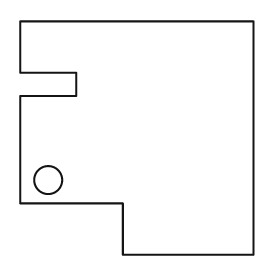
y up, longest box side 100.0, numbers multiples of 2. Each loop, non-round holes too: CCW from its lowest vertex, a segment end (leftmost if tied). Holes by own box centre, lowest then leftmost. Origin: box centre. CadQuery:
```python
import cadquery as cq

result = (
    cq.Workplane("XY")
    .moveTo(-6.0, -50.0)
    .lineTo(50.0, -50.0)
    .lineTo(50.0, 50.0)
    .lineTo(-50.0, 50.0)
    .lineTo(-50.0, 28.0)
    .lineTo(-26.0, 28.0)
    .lineTo(-26.0, 18.0)
    .lineTo(-50.0, 18.0)
    .lineTo(-50.0, -28.0)
    .lineTo(-6.0, -28.0)
    .close()
    .moveTo(-38.0, -18.0)
    .circle(6.0)
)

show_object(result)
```